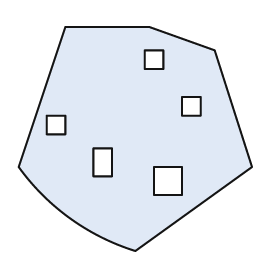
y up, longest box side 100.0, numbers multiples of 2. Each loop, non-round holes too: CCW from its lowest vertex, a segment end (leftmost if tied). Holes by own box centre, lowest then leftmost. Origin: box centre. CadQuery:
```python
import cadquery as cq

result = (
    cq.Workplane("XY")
    .moveTo(0.0, -48.0)
    .lineTo(50.0, -12.0)
    .lineTo(34.0, 38.0)
    .lineTo(6.0, 48.0)
    .lineTo(-30.0, 48.0)
    .lineTo(-50.0, -12.0)
    .threePointArc((-28.0, -34.0), (0.0, -48.0))
    .close()
    .moveTo(8.0, -24.0)
    .lineTo(20.0, -24.0)
    .lineTo(20.0, -12.0)
    .lineTo(8.0, -12.0)
    .close()
    .moveTo(-18.0, -16.0)
    .lineTo(-10.0, -16.0)
    .lineTo(-10.0, -4.0)
    .lineTo(-18.0, -4.0)
    .close()
    .moveTo(-38.0, 2.0)
    .lineTo(-30.0, 2.0)
    .lineTo(-30.0, 10.0)
    .lineTo(-38.0, 10.0)
    .close()
    .moveTo(20.0, 10.0)
    .lineTo(28.0, 10.0)
    .lineTo(28.0, 18.0)
    .lineTo(20.0, 18.0)
    .close()
    .moveTo(4.0, 30.0)
    .lineTo(12.0, 30.0)
    .lineTo(12.0, 38.0)
    .lineTo(4.0, 38.0)
    .close()
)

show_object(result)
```